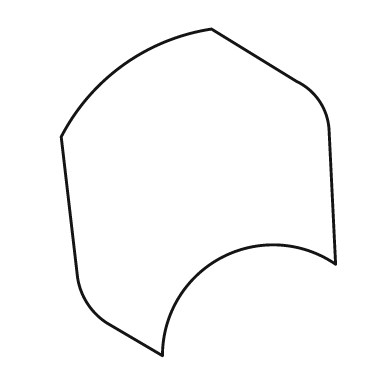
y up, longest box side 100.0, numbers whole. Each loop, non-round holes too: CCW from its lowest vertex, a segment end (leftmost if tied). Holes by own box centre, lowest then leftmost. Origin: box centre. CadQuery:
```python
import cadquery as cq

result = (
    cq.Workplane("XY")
    .moveTo(-11.0, -50.0)
    .threePointArc((7.0, -20.0), (42.0, -22.0))
    .lineTo(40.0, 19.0)
    .threePointArc((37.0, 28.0), (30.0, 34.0))
    .lineTo(4.0, 50.0)
    .threePointArc((-23.0, 39.0), (-42.0, 17.0))
    .lineTo(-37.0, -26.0)
    .threePointArc((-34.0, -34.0), (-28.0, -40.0))
    .close()
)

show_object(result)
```